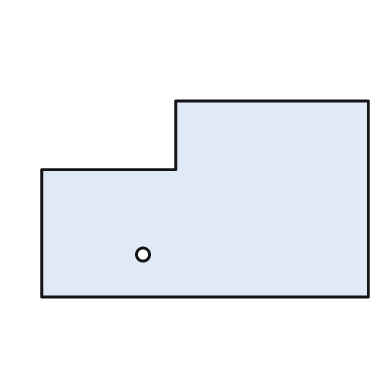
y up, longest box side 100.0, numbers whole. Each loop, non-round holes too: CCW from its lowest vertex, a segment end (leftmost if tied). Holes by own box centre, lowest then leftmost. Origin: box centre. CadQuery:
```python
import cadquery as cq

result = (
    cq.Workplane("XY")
    .moveTo(-50.0, -30.0)
    .lineTo(50.0, -30.0)
    .lineTo(50.0, 30.0)
    .lineTo(-9.0, 30.0)
    .lineTo(-9.0, 9.0)
    .lineTo(-50.0, 9.0)
    .close()
    .moveTo(-19.0, -17.0)
    .circle(2.0)
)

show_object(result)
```